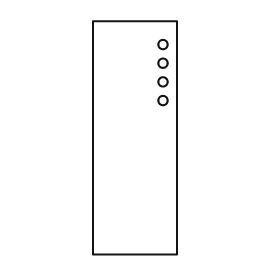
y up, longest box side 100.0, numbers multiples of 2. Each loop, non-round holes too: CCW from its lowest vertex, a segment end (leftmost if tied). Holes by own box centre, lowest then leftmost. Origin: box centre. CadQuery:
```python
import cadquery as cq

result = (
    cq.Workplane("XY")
    .moveTo(-18.0, -50.0)
    .lineTo(18.0, -50.0)
    .lineTo(18.0, 50.0)
    .lineTo(-18.0, 50.0)
    .close()
    .moveTo(12.0, 16.0)
    .circle(2.0)
    .moveTo(12.0, 24.0)
    .circle(2.0)
    .moveTo(12.0, 32.0)
    .circle(2.0)
    .moveTo(12.0, 40.0)
    .circle(2.0)
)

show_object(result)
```